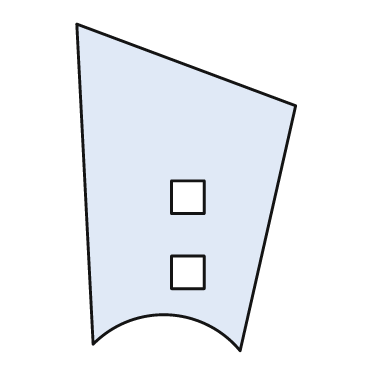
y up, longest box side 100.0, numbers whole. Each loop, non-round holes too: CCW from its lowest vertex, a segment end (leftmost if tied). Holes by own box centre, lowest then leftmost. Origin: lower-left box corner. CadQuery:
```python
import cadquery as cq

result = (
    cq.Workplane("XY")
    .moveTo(50.0, 0.0)
    .lineTo(67.0, 75.0)
    .lineTo(0.0, 100.0)
    .lineTo(5.0, 2.0)
    .threePointArc((28.0, 11.0), (50.0, 0.0))
    .close()
    .moveTo(29.0, 19.0)
    .lineTo(39.0, 19.0)
    .lineTo(39.0, 29.0)
    .lineTo(29.0, 29.0)
    .close()
    .moveTo(29.0, 42.0)
    .lineTo(39.0, 42.0)
    .lineTo(39.0, 52.0)
    .lineTo(29.0, 52.0)
    .close()
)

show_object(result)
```